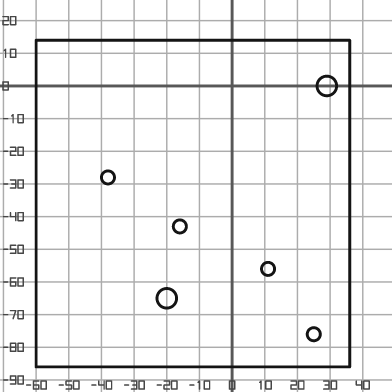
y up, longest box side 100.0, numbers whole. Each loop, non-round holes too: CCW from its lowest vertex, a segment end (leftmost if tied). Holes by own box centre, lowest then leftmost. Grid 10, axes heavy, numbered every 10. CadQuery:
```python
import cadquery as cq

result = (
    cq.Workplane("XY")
    .moveTo(-60.0, -86.0)
    .lineTo(36.0, -86.0)
    .lineTo(36.0, 14.0)
    .lineTo(-60.0, 14.0)
    .close()
    .moveTo(25.0, -76.0)
    .circle(2.0)
    .moveTo(-20.0, -65.0)
    .circle(3.0)
    .moveTo(11.0, -56.0)
    .circle(2.0)
    .moveTo(-16.0, -43.0)
    .circle(2.0)
    .moveTo(-38.0, -28.0)
    .circle(2.0)
    .moveTo(29.0, 0.0)
    .circle(3.0)
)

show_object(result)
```